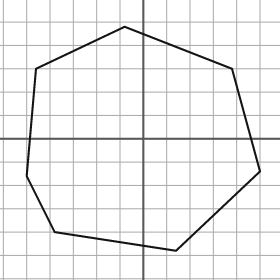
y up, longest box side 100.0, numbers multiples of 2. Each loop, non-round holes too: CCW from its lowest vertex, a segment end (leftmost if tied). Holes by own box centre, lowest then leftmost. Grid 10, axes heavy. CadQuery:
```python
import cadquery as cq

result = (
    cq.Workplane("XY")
    .moveTo(14.0, -48.0)
    .lineTo(50.0, -14.0)
    .lineTo(38.0, 30.0)
    .lineTo(-8.0, 48.0)
    .lineTo(-46.0, 30.0)
    .lineTo(-50.0, -16.0)
    .lineTo(-38.0, -40.0)
    .close()
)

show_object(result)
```